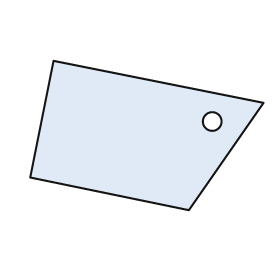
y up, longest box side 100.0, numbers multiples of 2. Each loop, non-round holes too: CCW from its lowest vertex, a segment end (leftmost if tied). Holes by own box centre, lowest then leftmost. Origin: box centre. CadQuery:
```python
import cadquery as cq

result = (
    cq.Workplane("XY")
    .moveTo(18.0, -32.0)
    .lineTo(50.0, 14.0)
    .lineTo(-40.0, 32.0)
    .lineTo(-50.0, -18.0)
    .close()
    .moveTo(28.0, 6.0)
    .circle(4.0)
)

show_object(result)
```